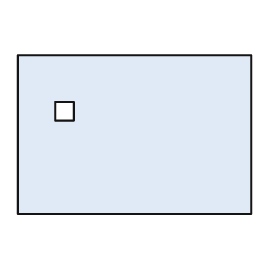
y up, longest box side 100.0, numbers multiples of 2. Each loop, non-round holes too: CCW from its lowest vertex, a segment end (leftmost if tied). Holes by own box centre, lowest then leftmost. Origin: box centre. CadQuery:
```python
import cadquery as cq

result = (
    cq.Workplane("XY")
    .moveTo(-50.0, -34.0)
    .lineTo(50.0, -34.0)
    .lineTo(50.0, 34.0)
    .lineTo(-50.0, 34.0)
    .close()
    .moveTo(-34.0, 6.0)
    .lineTo(-26.0, 6.0)
    .lineTo(-26.0, 14.0)
    .lineTo(-34.0, 14.0)
    .close()
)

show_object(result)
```